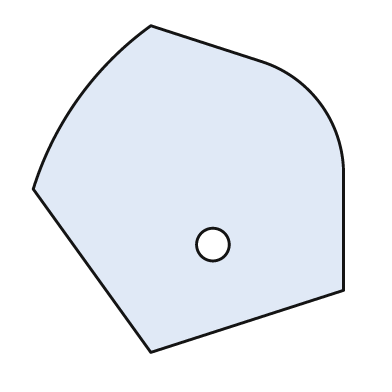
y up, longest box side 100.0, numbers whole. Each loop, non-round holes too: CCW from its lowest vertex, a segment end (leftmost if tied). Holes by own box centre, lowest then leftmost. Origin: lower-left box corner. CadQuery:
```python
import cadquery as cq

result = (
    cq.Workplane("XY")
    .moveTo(36.0, 0.0)
    .lineTo(95.0, 19.0)
    .lineTo(95.0, 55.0)
    .threePointArc((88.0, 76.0), (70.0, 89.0))
    .lineTo(36.0, 100.0)
    .threePointArc((14.0, 78.0), (0.0, 50.0))
    .close()
    .moveTo(55.0, 33.0)
    .circle(5.0)
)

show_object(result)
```